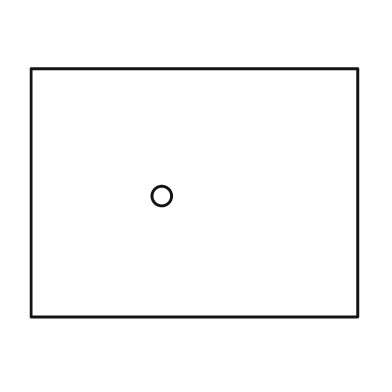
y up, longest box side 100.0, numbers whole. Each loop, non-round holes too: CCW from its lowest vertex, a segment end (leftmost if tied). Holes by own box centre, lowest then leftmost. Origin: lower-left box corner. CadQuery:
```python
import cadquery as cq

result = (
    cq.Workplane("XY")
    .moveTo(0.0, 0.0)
    .lineTo(100.0, 0.0)
    .lineTo(100.0, 76.0)
    .lineTo(0.0, 76.0)
    .close()
    .moveTo(40.0, 37.0)
    .circle(3.0)
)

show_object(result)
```